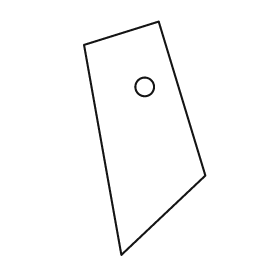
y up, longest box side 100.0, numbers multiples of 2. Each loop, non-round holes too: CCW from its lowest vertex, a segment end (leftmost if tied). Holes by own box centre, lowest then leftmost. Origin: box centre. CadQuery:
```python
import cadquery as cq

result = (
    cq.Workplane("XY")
    .moveTo(-10.0, -50.0)
    .lineTo(26.0, -16.0)
    .lineTo(6.0, 50.0)
    .lineTo(-26.0, 40.0)
    .close()
    .moveTo(0.0, 22.0)
    .circle(4.0)
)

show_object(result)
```